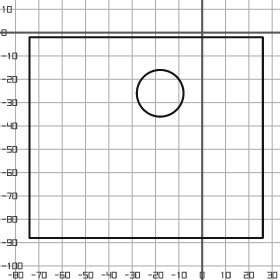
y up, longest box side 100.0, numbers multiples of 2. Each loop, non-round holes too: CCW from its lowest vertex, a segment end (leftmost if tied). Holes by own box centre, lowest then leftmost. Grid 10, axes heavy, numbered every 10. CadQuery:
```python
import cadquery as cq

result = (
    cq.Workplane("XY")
    .moveTo(-74.0, -88.0)
    .lineTo(26.0, -88.0)
    .lineTo(26.0, -2.0)
    .lineTo(-74.0, -2.0)
    .close()
    .moveTo(-18.0, -26.0)
    .circle(10.0)
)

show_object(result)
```